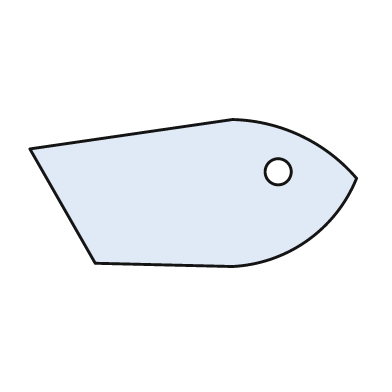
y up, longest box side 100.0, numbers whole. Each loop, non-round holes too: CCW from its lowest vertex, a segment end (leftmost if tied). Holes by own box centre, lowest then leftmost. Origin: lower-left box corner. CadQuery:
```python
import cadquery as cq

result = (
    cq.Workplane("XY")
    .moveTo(62.0, 0.0)
    .threePointArc((85.0, 8.0), (100.0, 27.0))
    .threePointArc((83.0, 40.0), (62.0, 45.0))
    .lineTo(0.0, 36.0)
    .lineTo(20.0, 1.0)
    .close()
    .moveTo(76.0, 29.0)
    .circle(4.0)
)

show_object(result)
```